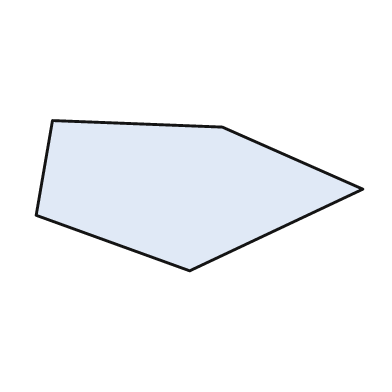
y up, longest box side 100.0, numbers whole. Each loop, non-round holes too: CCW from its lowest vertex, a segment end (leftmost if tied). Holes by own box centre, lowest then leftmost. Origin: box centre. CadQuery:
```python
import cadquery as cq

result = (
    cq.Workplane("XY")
    .moveTo(-3.0, -23.0)
    .lineTo(50.0, 2.0)
    .lineTo(7.0, 21.0)
    .lineTo(-45.0, 23.0)
    .lineTo(-50.0, -6.0)
    .close()
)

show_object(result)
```